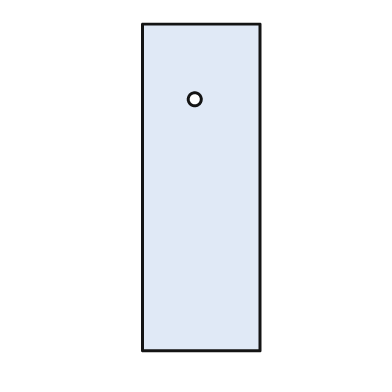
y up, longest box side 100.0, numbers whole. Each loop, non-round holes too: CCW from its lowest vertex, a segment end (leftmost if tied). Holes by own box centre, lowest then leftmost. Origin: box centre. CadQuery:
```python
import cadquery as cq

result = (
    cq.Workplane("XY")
    .moveTo(-18.0, -50.0)
    .lineTo(18.0, -50.0)
    .lineTo(18.0, 50.0)
    .lineTo(-18.0, 50.0)
    .close()
    .moveTo(-2.0, 27.0)
    .circle(2.0)
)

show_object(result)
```